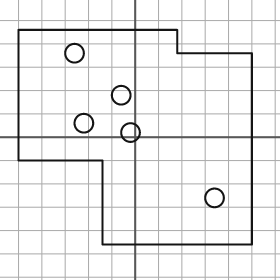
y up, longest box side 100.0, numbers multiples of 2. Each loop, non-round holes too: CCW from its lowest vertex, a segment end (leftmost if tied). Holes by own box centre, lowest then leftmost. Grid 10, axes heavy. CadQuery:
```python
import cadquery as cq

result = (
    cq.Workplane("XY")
    .moveTo(-14.0, -46.0)
    .lineTo(50.0, -46.0)
    .lineTo(50.0, 36.0)
    .lineTo(18.0, 36.0)
    .lineTo(18.0, 46.0)
    .lineTo(-50.0, 46.0)
    .lineTo(-50.0, -10.0)
    .lineTo(-14.0, -10.0)
    .close()
    .moveTo(34.0, -26.0)
    .circle(4.0)
    .moveTo(-2.0, 2.0)
    .circle(4.0)
    .moveTo(-22.0, 6.0)
    .circle(4.0)
    .moveTo(-6.0, 18.0)
    .circle(4.0)
    .moveTo(-26.0, 36.0)
    .circle(4.0)
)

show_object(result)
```